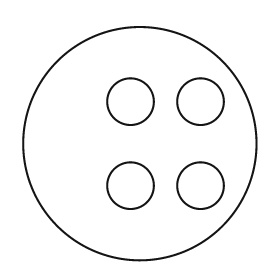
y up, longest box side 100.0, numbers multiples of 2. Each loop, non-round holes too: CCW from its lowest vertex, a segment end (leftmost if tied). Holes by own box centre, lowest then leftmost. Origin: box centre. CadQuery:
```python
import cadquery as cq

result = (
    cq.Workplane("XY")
    .moveTo(0.0, 0.0)
    .circle(50.0)
    .moveTo(-4.0, -18.0)
    .circle(10.0)
    .moveTo(26.0, -18.0)
    .circle(10.0)
    .moveTo(-4.0, 18.0)
    .circle(10.0)
    .moveTo(26.0, 18.0)
    .circle(10.0)
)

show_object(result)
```